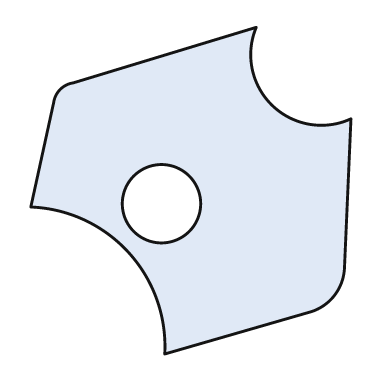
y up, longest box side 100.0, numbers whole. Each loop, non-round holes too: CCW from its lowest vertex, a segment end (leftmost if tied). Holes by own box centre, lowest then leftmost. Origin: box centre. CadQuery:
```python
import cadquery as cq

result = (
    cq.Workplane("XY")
    .moveTo(-8.0, -50.0)
    .lineTo(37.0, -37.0)
    .threePointArc((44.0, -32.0), (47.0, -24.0))
    .lineTo(49.0, 22.0)
    .threePointArc((25.0, 26.0), (20.0, 50.0))
    .lineTo(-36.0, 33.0)
    .threePointArc((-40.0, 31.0), (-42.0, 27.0))
    .lineTo(-49.0, -5.0)
    .threePointArc((-19.0, -19.0), (-8.0, -50.0))
    .close()
    .moveTo(-9.0, -4.0)
    .circle(12.0)
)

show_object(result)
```